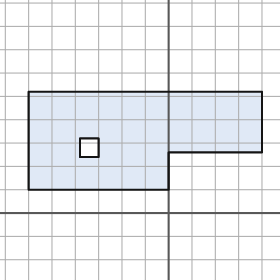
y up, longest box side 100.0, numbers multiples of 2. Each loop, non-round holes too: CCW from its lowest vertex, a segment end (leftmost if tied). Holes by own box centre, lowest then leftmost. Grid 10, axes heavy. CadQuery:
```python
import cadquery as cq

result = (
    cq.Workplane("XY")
    .moveTo(-60.0, 10.0)
    .lineTo(0.0, 10.0)
    .lineTo(0.0, 26.0)
    .lineTo(40.0, 26.0)
    .lineTo(40.0, 52.0)
    .lineTo(-60.0, 52.0)
    .close()
    .moveTo(-38.0, 24.0)
    .lineTo(-30.0, 24.0)
    .lineTo(-30.0, 32.0)
    .lineTo(-38.0, 32.0)
    .close()
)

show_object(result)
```